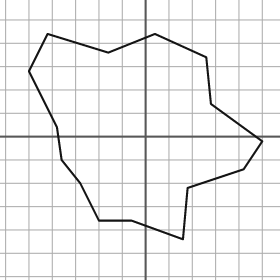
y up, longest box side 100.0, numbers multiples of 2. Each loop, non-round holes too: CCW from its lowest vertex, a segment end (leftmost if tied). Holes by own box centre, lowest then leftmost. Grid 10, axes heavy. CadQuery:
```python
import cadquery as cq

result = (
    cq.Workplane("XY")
    .moveTo(16.0, -44.0)
    .lineTo(18.0, -22.0)
    .lineTo(42.0, -14.0)
    .lineTo(50.0, -2.0)
    .lineTo(28.0, 14.0)
    .lineTo(26.0, 34.0)
    .lineTo(4.0, 44.0)
    .lineTo(-16.0, 36.0)
    .lineTo(-42.0, 44.0)
    .lineTo(-50.0, 28.0)
    .lineTo(-38.0, 4.0)
    .lineTo(-36.0, -10.0)
    .lineTo(-28.0, -20.0)
    .lineTo(-20.0, -36.0)
    .lineTo(-6.0, -36.0)
    .close()
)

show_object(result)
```